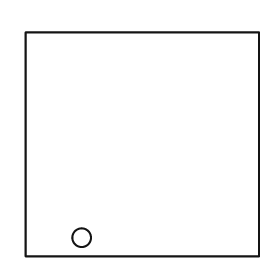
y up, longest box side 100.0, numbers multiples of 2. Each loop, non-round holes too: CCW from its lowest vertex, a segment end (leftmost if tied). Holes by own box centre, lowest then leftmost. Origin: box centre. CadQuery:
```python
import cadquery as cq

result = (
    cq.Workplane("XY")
    .moveTo(-50.0, -48.0)
    .lineTo(50.0, -48.0)
    .lineTo(50.0, 48.0)
    .lineTo(-50.0, 48.0)
    .close()
    .moveTo(-26.0, -40.0)
    .circle(4.0)
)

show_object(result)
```